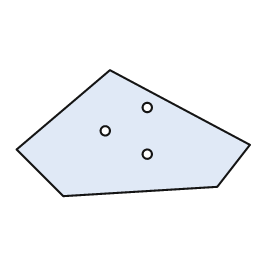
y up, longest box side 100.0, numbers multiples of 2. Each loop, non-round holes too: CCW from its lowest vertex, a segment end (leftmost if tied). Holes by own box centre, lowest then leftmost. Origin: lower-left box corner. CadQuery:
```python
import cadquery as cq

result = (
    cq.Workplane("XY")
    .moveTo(20.0, 0.0)
    .lineTo(86.0, 4.0)
    .lineTo(100.0, 22.0)
    .lineTo(40.0, 54.0)
    .lineTo(0.0, 20.0)
    .close()
    .moveTo(56.0, 18.0)
    .circle(2.0)
    .moveTo(38.0, 28.0)
    .circle(2.0)
    .moveTo(56.0, 38.0)
    .circle(2.0)
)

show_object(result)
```